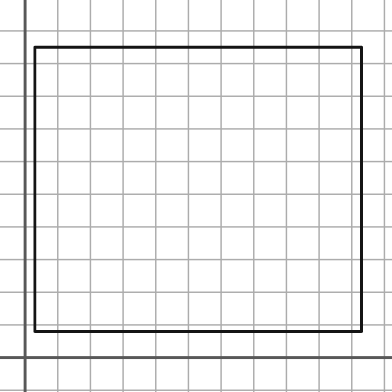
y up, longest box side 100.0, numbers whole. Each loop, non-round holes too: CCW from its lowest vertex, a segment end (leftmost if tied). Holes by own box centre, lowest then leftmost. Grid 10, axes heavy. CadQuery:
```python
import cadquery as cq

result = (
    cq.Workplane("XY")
    .moveTo(3.0, 8.0)
    .lineTo(103.0, 8.0)
    .lineTo(103.0, 95.0)
    .lineTo(3.0, 95.0)
    .close()
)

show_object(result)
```